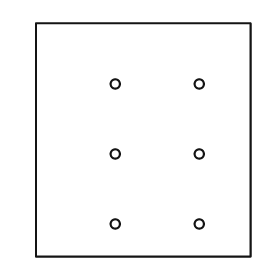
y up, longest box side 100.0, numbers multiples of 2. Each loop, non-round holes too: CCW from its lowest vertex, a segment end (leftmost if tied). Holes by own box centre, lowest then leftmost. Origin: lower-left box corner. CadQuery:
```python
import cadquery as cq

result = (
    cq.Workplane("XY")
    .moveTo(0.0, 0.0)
    .lineTo(92.0, 0.0)
    .lineTo(92.0, 100.0)
    .lineTo(0.0, 100.0)
    .close()
    .moveTo(34.0, 14.0)
    .circle(2.0)
    .moveTo(70.0, 14.0)
    .circle(2.0)
    .moveTo(34.0, 44.0)
    .circle(2.0)
    .moveTo(70.0, 44.0)
    .circle(2.0)
    .moveTo(34.0, 74.0)
    .circle(2.0)
    .moveTo(70.0, 74.0)
    .circle(2.0)
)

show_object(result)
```